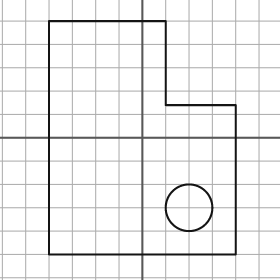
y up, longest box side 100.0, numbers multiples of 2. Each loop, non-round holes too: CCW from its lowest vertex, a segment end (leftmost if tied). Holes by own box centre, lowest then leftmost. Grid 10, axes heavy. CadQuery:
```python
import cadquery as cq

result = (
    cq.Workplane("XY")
    .moveTo(-40.0, -50.0)
    .lineTo(40.0, -50.0)
    .lineTo(40.0, 14.0)
    .lineTo(10.0, 14.0)
    .lineTo(10.0, 50.0)
    .lineTo(-40.0, 50.0)
    .close()
    .moveTo(20.0, -30.0)
    .circle(10.0)
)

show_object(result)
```